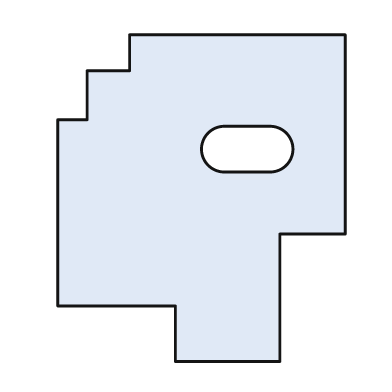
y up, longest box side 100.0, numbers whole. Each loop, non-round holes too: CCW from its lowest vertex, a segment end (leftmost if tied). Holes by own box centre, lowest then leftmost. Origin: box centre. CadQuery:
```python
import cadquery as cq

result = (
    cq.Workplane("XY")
    .moveTo(-8.0, -50.0)
    .lineTo(24.0, -50.0)
    .lineTo(24.0, -11.0)
    .lineTo(44.0, -11.0)
    .lineTo(44.0, 50.0)
    .lineTo(-22.0, 50.0)
    .lineTo(-22.0, 39.0)
    .lineTo(-35.0, 39.0)
    .lineTo(-35.0, 24.0)
    .lineTo(-44.0, 24.0)
    .lineTo(-44.0, -33.0)
    .lineTo(-8.0, -33.0)
    .close()
    .moveTo(7.0, 8.0)
    .lineTo(21.0, 8.0)
    .threePointArc((28.0, 15.0), (21.0, 22.0))
    .lineTo(7.0, 22.0)
    .threePointArc((0.0, 15.0), (7.0, 8.0))
    .close()
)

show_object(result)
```